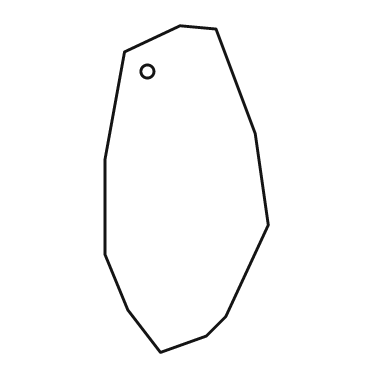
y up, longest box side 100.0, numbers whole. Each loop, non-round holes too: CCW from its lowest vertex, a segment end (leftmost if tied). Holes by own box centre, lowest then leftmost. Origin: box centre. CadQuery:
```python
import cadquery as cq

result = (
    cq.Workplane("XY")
    .moveTo(-8.0, -50.0)
    .lineTo(6.0, -45.0)
    .lineTo(12.0, -39.0)
    .lineTo(25.0, -11.0)
    .lineTo(21.0, 17.0)
    .lineTo(9.0, 49.0)
    .lineTo(-2.0, 50.0)
    .lineTo(-19.0, 42.0)
    .lineTo(-25.0, 9.0)
    .lineTo(-25.0, -20.0)
    .lineTo(-18.0, -37.0)
    .close()
    .moveTo(-12.0, 36.0)
    .circle(2.0)
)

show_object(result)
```